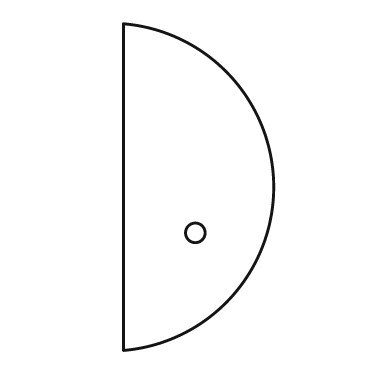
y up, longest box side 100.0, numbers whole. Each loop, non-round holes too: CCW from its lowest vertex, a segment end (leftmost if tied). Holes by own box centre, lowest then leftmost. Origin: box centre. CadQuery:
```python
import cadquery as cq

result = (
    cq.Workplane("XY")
    .moveTo(-23.0, -50.0)
    .threePointArc((23.0, 0.0), (-23.0, 50.0))
    .close()
    .moveTo(-1.0, -14.0)
    .circle(3.0)
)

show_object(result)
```